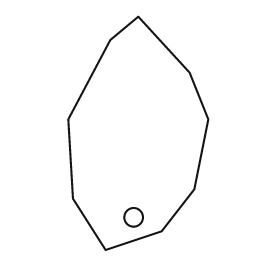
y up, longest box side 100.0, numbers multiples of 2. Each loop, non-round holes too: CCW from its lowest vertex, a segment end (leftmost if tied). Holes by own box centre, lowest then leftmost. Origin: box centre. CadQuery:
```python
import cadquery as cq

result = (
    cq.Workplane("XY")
    .moveTo(-14.0, -50.0)
    .lineTo(10.0, -42.0)
    .lineTo(24.0, -24.0)
    .lineTo(30.0, 6.0)
    .lineTo(22.0, 26.0)
    .lineTo(0.0, 50.0)
    .lineTo(-12.0, 40.0)
    .lineTo(-30.0, 6.0)
    .lineTo(-28.0, -28.0)
    .close()
    .moveTo(-2.0, -36.0)
    .circle(4.0)
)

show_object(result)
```